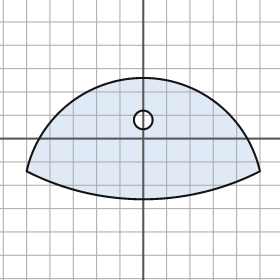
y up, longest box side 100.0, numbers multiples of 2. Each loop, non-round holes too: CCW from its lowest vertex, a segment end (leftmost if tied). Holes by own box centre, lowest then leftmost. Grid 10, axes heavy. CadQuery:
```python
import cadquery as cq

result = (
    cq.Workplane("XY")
    .moveTo(-50.0, -14.0)
    .threePointArc((0.0, -26.0), (50.0, -14.0))
    .threePointArc((0.0, 26.0), (-50.0, -14.0))
    .close()
    .moveTo(0.0, 8.0)
    .circle(4.0)
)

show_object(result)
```